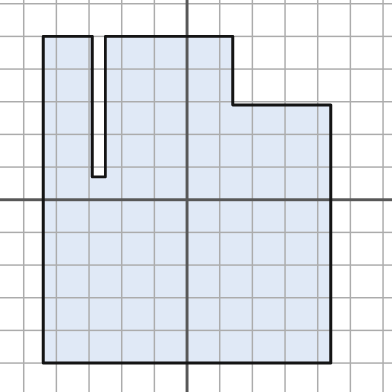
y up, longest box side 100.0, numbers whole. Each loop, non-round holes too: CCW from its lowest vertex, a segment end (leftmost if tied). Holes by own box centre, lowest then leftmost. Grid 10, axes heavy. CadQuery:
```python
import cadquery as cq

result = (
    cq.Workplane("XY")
    .moveTo(-44.0, -50.0)
    .lineTo(44.0, -50.0)
    .lineTo(44.0, 29.0)
    .lineTo(14.0, 29.0)
    .lineTo(14.0, 50.0)
    .lineTo(-25.0, 50.0)
    .lineTo(-25.0, 7.0)
    .lineTo(-29.0, 7.0)
    .lineTo(-29.0, 50.0)
    .lineTo(-44.0, 50.0)
    .close()
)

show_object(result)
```